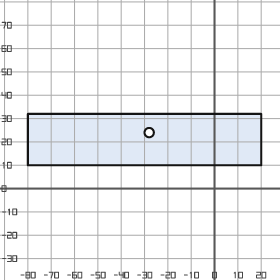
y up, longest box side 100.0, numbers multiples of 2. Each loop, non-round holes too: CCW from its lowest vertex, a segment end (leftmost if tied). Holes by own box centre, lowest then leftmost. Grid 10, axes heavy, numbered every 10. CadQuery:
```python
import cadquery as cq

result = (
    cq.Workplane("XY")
    .moveTo(-80.0, 10.0)
    .lineTo(20.0, 10.0)
    .lineTo(20.0, 32.0)
    .lineTo(-80.0, 32.0)
    .close()
    .moveTo(-28.0, 24.0)
    .circle(2.0)
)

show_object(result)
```